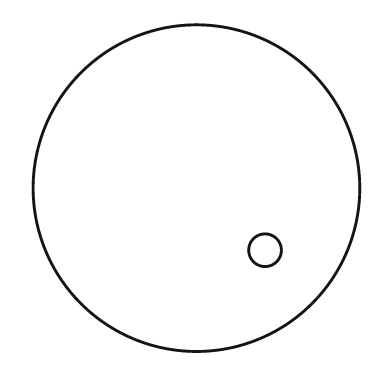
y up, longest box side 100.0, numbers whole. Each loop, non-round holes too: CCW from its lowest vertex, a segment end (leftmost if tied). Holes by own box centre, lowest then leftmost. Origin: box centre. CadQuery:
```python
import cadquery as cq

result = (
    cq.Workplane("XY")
    .moveTo(0.0, 0.0)
    .circle(50.0)
    .moveTo(21.0, -19.0)
    .circle(5.0)
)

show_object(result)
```